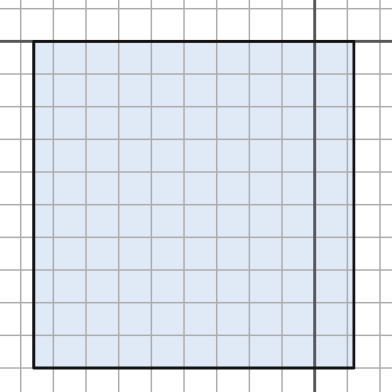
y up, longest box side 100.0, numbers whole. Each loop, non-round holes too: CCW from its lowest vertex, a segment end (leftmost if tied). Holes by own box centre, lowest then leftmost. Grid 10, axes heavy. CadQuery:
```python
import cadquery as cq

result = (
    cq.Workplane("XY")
    .moveTo(-86.0, -100.0)
    .lineTo(12.0, -100.0)
    .lineTo(12.0, 0.0)
    .lineTo(-86.0, 0.0)
    .close()
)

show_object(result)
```